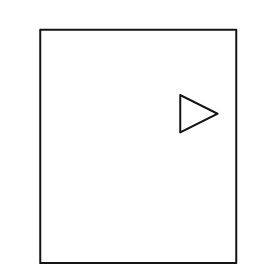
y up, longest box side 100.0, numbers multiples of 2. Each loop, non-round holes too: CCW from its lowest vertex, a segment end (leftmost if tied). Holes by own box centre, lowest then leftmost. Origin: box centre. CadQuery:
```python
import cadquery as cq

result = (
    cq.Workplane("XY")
    .moveTo(-42.0, -50.0)
    .lineTo(42.0, -50.0)
    .lineTo(42.0, 50.0)
    .lineTo(-42.0, 50.0)
    .close()
    .moveTo(18.0, 6.0)
    .lineTo(34.0, 14.0)
    .lineTo(18.0, 22.0)
    .close()
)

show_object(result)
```